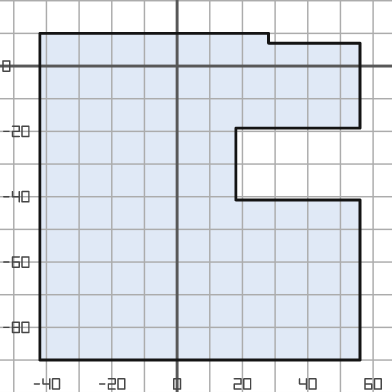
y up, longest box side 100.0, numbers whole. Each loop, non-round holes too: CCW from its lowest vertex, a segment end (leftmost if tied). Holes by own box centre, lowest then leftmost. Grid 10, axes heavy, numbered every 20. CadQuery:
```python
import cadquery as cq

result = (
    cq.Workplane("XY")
    .moveTo(-42.0, -90.0)
    .lineTo(56.0, -90.0)
    .lineTo(56.0, -41.0)
    .lineTo(18.0, -41.0)
    .lineTo(18.0, -19.0)
    .lineTo(56.0, -19.0)
    .lineTo(56.0, 7.0)
    .lineTo(28.0, 7.0)
    .lineTo(28.0, 10.0)
    .lineTo(-42.0, 10.0)
    .close()
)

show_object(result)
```